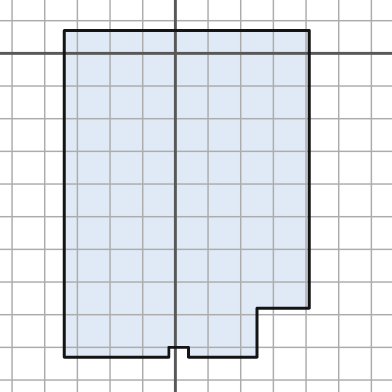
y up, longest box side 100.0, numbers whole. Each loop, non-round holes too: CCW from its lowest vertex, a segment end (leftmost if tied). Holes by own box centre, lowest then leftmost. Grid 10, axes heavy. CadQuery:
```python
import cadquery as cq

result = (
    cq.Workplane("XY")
    .moveTo(-34.0, -93.0)
    .lineTo(-2.0, -93.0)
    .lineTo(-2.0, -90.0)
    .lineTo(4.0, -90.0)
    .lineTo(4.0, -93.0)
    .lineTo(25.0, -93.0)
    .lineTo(25.0, -78.0)
    .lineTo(41.0, -78.0)
    .lineTo(41.0, 7.0)
    .lineTo(-34.0, 7.0)
    .close()
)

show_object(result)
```